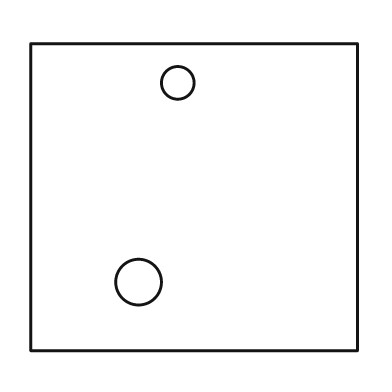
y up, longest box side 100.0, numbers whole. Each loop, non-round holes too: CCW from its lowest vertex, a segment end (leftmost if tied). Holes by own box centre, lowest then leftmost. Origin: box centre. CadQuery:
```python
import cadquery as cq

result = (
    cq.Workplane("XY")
    .moveTo(-50.0, -47.0)
    .lineTo(50.0, -47.0)
    .lineTo(50.0, 47.0)
    .lineTo(-50.0, 47.0)
    .close()
    .moveTo(-17.0, -26.0)
    .circle(7.0)
    .moveTo(-5.0, 35.0)
    .circle(5.0)
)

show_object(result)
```